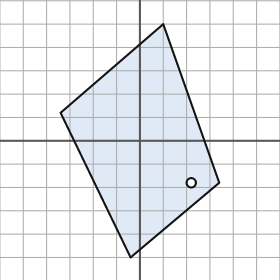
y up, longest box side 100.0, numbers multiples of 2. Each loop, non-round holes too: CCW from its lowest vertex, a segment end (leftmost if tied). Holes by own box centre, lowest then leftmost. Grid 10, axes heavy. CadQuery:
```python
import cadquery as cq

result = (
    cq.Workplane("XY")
    .moveTo(-4.0, -50.0)
    .lineTo(34.0, -18.0)
    .lineTo(10.0, 50.0)
    .lineTo(-34.0, 12.0)
    .close()
    .moveTo(22.0, -18.0)
    .circle(2.0)
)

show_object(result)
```